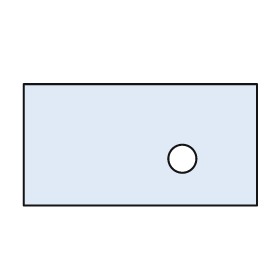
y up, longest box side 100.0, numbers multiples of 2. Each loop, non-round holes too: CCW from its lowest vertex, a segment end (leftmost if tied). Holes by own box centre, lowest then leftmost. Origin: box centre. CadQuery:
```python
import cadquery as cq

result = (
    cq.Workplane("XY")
    .moveTo(-50.0, -26.0)
    .lineTo(50.0, -26.0)
    .lineTo(50.0, 26.0)
    .lineTo(-50.0, 26.0)
    .close()
    .moveTo(18.0, -6.0)
    .circle(6.0)
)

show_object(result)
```